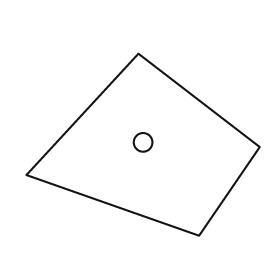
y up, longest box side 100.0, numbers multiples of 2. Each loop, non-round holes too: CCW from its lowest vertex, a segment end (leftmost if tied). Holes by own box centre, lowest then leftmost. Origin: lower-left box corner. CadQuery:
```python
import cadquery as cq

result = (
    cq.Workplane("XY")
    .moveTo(74.0, 0.0)
    .lineTo(100.0, 38.0)
    .lineTo(48.0, 78.0)
    .lineTo(0.0, 26.0)
    .close()
    .moveTo(50.0, 40.0)
    .circle(4.0)
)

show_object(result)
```